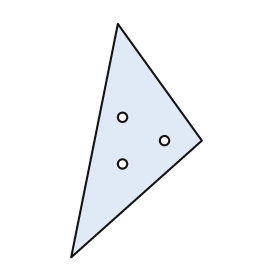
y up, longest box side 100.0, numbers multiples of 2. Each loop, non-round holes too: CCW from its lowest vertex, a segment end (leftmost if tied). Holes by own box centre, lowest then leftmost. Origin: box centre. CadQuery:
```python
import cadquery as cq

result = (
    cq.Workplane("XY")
    .moveTo(-28.0, -50.0)
    .lineTo(28.0, 0.0)
    .lineTo(-8.0, 50.0)
    .close()
    .moveTo(-6.0, -10.0)
    .circle(2.0)
    .moveTo(12.0, 0.0)
    .circle(2.0)
    .moveTo(-6.0, 10.0)
    .circle(2.0)
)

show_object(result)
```